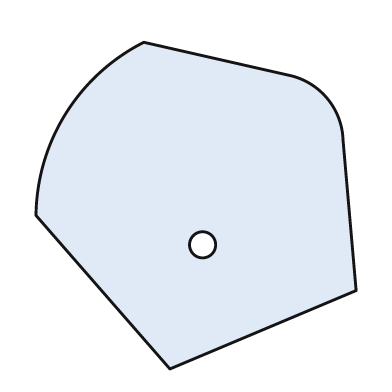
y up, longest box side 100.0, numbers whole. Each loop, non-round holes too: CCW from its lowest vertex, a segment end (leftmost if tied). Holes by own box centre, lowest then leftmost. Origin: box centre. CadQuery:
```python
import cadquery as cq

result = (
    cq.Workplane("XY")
    .moveTo(-8.0, -50.0)
    .lineTo(49.0, -26.0)
    .lineTo(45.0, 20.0)
    .threePointArc((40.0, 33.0), (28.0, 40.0))
    .lineTo(-16.0, 50.0)
    .threePointArc((-40.0, 28.0), (-49.0, -3.0))
    .close()
    .moveTo(2.0, -12.0)
    .circle(4.0)
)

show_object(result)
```